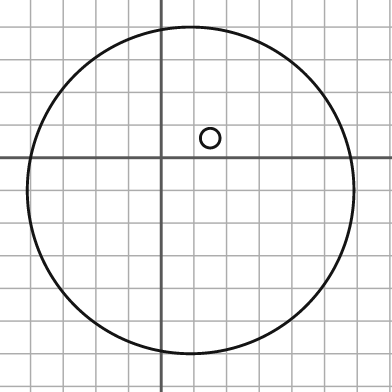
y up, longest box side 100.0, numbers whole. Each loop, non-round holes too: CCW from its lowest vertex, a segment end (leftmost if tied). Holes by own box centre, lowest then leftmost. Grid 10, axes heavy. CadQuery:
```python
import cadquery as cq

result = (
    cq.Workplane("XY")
    .moveTo(9.0, -10.0)
    .circle(50.0)
    .moveTo(15.0, 6.0)
    .circle(3.0)
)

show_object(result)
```